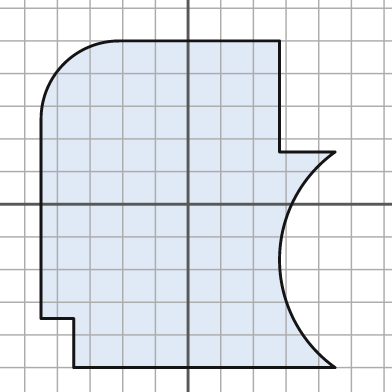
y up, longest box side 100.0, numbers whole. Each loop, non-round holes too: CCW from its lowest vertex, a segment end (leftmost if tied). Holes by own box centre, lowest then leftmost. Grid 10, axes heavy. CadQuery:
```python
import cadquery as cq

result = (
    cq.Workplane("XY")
    .moveTo(-35.0, -50.0)
    .lineTo(45.0, -50.0)
    .threePointArc((28.0, -17.0), (45.0, 16.0))
    .lineTo(28.0, 16.0)
    .lineTo(28.0, 50.0)
    .lineTo(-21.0, 50.0)
    .threePointArc((-38.0, 43.0), (-45.0, 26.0))
    .lineTo(-45.0, -35.0)
    .lineTo(-35.0, -35.0)
    .close()
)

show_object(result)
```